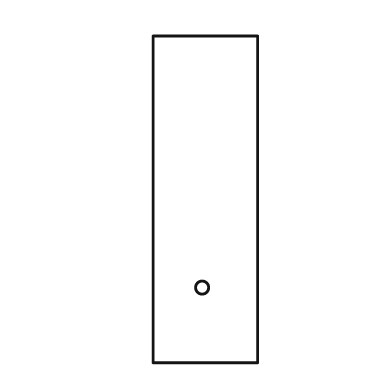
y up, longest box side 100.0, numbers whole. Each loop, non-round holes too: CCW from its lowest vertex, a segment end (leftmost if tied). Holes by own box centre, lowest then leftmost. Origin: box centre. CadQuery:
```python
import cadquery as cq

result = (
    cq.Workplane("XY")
    .moveTo(-16.0, -50.0)
    .lineTo(16.0, -50.0)
    .lineTo(16.0, 50.0)
    .lineTo(-16.0, 50.0)
    .close()
    .moveTo(-1.0, -27.0)
    .circle(2.0)
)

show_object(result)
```